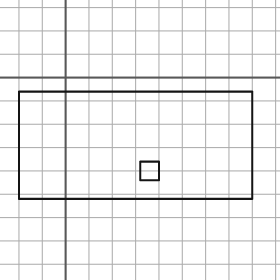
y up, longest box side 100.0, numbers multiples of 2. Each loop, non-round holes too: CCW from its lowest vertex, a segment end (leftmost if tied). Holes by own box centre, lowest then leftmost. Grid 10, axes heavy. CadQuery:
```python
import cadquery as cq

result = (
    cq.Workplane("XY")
    .moveTo(-20.0, -52.0)
    .lineTo(80.0, -52.0)
    .lineTo(80.0, -6.0)
    .lineTo(-20.0, -6.0)
    .close()
    .moveTo(32.0, -44.0)
    .lineTo(40.0, -44.0)
    .lineTo(40.0, -36.0)
    .lineTo(32.0, -36.0)
    .close()
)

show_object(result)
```